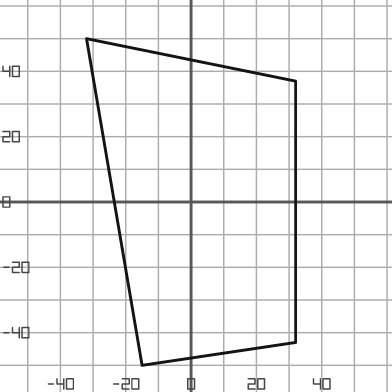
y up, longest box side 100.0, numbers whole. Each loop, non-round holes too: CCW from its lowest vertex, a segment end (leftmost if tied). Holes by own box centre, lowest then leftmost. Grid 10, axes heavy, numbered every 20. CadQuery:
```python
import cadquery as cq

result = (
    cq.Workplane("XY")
    .moveTo(-15.0, -50.0)
    .lineTo(32.0, -43.0)
    .lineTo(32.0, 37.0)
    .lineTo(-32.0, 50.0)
    .close()
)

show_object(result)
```